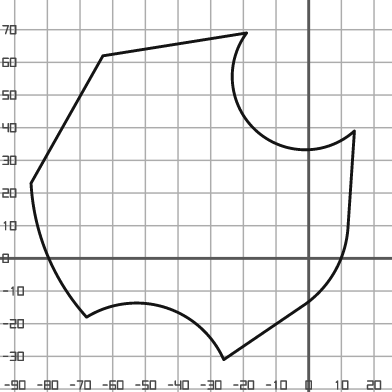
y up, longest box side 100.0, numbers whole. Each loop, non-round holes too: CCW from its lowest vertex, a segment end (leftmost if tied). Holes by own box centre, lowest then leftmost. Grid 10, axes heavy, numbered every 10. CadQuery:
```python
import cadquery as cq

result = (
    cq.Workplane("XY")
    .moveTo(-26.0, -31.0)
    .lineTo(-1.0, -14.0)
    .threePointArc((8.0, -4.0), (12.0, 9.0))
    .lineTo(14.0, 39.0)
    .threePointArc((-16.0, 39.0), (-19.0, 69.0))
    .lineTo(-63.0, 62.0)
    .lineTo(-85.0, 23.0)
    .threePointArc((-80.0, 1.0), (-68.0, -18.0))
    .threePointArc((-44.0, -15.0), (-26.0, -31.0))
    .close()
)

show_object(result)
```